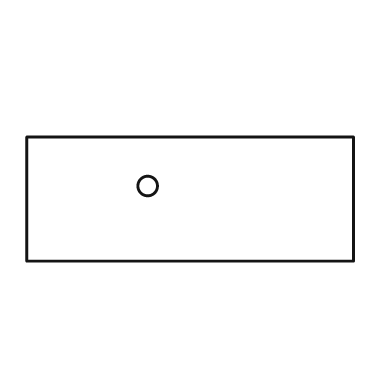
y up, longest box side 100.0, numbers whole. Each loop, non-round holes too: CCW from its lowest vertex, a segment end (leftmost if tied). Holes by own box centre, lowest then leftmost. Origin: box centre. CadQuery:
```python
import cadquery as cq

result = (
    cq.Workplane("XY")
    .moveTo(-50.0, -19.0)
    .lineTo(50.0, -19.0)
    .lineTo(50.0, 19.0)
    .lineTo(-50.0, 19.0)
    .close()
    .moveTo(-13.0, 4.0)
    .circle(3.0)
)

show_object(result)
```